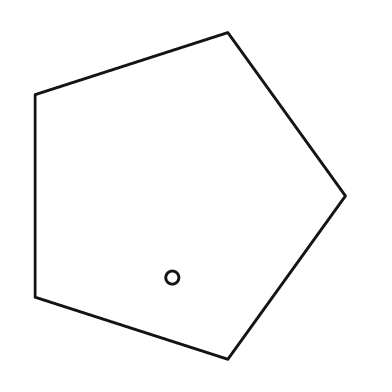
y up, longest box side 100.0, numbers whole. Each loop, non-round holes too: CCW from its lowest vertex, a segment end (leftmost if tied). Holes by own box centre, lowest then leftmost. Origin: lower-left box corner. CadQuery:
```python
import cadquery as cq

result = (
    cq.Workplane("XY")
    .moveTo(59.0, 0.0)
    .lineTo(95.0, 50.0)
    .lineTo(59.0, 100.0)
    .lineTo(0.0, 81.0)
    .lineTo(0.0, 19.0)
    .close()
    .moveTo(42.0, 25.0)
    .circle(2.0)
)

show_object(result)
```